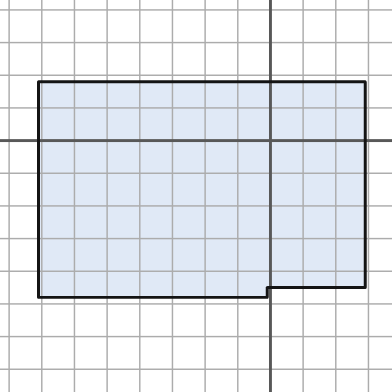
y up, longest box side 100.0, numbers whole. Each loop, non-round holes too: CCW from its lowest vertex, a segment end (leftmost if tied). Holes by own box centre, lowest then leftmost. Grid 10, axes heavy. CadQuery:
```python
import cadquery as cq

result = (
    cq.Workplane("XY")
    .moveTo(-71.0, -48.0)
    .lineTo(-1.0, -48.0)
    .lineTo(-1.0, -45.0)
    .lineTo(29.0, -45.0)
    .lineTo(29.0, 18.0)
    .lineTo(-71.0, 18.0)
    .close()
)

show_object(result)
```